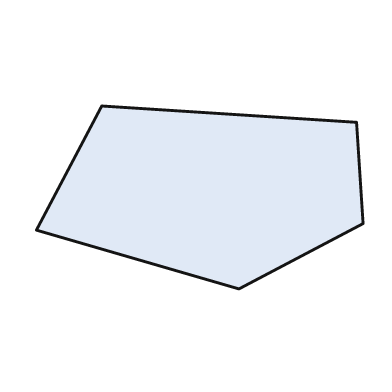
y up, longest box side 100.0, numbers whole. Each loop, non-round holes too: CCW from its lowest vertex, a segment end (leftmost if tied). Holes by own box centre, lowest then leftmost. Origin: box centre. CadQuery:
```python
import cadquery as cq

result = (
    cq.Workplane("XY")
    .moveTo(12.0, -28.0)
    .lineTo(50.0, -8.0)
    .lineTo(48.0, 23.0)
    .lineTo(-30.0, 28.0)
    .lineTo(-50.0, -10.0)
    .close()
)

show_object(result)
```